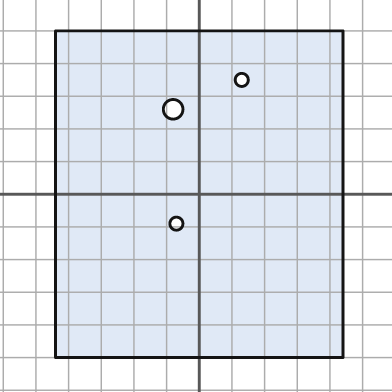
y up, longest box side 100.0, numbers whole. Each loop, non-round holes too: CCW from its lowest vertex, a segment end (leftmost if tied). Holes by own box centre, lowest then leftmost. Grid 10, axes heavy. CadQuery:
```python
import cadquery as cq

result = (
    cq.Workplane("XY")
    .moveTo(-44.0, -50.0)
    .lineTo(44.0, -50.0)
    .lineTo(44.0, 50.0)
    .lineTo(-44.0, 50.0)
    .close()
    .moveTo(-7.0, -9.0)
    .circle(2.0)
    .moveTo(-8.0, 26.0)
    .circle(3.0)
    .moveTo(13.0, 35.0)
    .circle(2.0)
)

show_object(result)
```